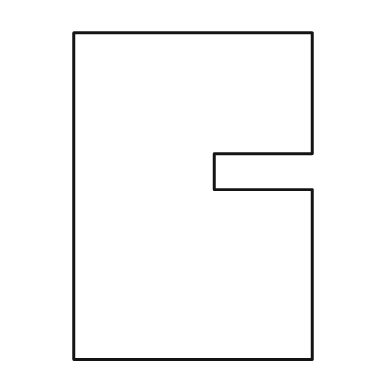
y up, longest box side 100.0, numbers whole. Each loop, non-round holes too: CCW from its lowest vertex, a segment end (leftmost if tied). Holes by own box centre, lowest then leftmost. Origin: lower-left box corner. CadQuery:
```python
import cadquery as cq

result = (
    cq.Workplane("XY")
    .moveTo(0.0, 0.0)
    .lineTo(73.0, 0.0)
    .lineTo(73.0, 52.0)
    .lineTo(43.0, 52.0)
    .lineTo(43.0, 63.0)
    .lineTo(73.0, 63.0)
    .lineTo(73.0, 100.0)
    .lineTo(0.0, 100.0)
    .close()
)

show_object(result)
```